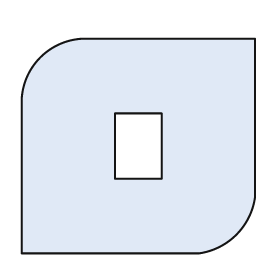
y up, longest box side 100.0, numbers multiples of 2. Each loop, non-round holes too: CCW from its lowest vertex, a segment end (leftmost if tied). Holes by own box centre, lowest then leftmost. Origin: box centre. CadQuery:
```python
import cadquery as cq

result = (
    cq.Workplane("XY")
    .moveTo(-50.0, -46.0)
    .lineTo(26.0, -46.0)
    .threePointArc((42.0, -38.0), (50.0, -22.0))
    .lineTo(50.0, 46.0)
    .lineTo(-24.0, 46.0)
    .threePointArc((-42.0, 38.0), (-50.0, 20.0))
    .close()
    .moveTo(-10.0, -14.0)
    .lineTo(10.0, -14.0)
    .lineTo(10.0, 14.0)
    .lineTo(-10.0, 14.0)
    .close()
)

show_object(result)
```